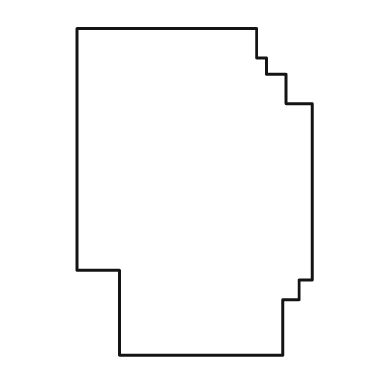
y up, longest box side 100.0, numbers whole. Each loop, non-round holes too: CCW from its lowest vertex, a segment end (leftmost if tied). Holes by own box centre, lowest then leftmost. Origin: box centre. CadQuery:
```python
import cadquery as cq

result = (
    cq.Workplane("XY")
    .moveTo(-23.0, -50.0)
    .lineTo(27.0, -50.0)
    .lineTo(27.0, -33.0)
    .lineTo(32.0, -33.0)
    .lineTo(32.0, -27.0)
    .lineTo(36.0, -27.0)
    .lineTo(36.0, 27.0)
    .lineTo(28.0, 27.0)
    .lineTo(28.0, 36.0)
    .lineTo(22.0, 36.0)
    .lineTo(22.0, 41.0)
    .lineTo(19.0, 41.0)
    .lineTo(19.0, 50.0)
    .lineTo(-36.0, 50.0)
    .lineTo(-36.0, -24.0)
    .lineTo(-23.0, -24.0)
    .close()
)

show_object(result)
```